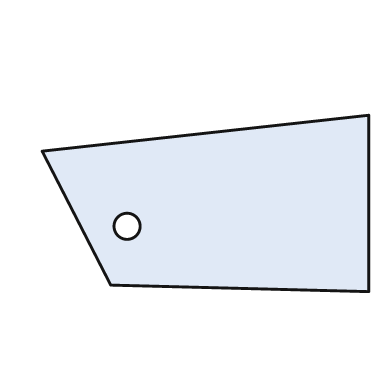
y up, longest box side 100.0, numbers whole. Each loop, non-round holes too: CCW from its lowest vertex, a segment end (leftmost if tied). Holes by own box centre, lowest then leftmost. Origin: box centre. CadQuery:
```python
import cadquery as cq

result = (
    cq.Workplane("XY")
    .moveTo(50.0, -27.0)
    .lineTo(50.0, 27.0)
    .lineTo(-50.0, 16.0)
    .lineTo(-29.0, -25.0)
    .close()
    .moveTo(-24.0, -7.0)
    .circle(4.0)
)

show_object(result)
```